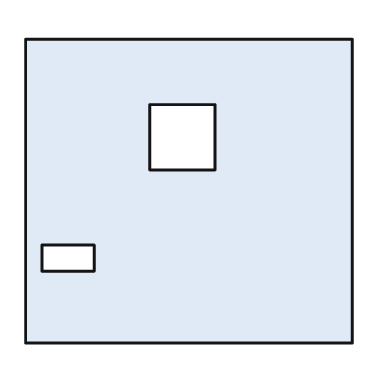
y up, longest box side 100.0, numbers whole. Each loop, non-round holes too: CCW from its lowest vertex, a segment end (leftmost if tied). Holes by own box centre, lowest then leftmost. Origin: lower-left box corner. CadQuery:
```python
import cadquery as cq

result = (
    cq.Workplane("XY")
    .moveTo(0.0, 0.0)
    .lineTo(100.0, 0.0)
    .lineTo(100.0, 93.0)
    .lineTo(0.0, 93.0)
    .close()
    .moveTo(5.0, 22.0)
    .lineTo(21.0, 22.0)
    .lineTo(21.0, 30.0)
    .lineTo(5.0, 30.0)
    .close()
    .moveTo(38.0, 53.0)
    .lineTo(58.0, 53.0)
    .lineTo(58.0, 73.0)
    .lineTo(38.0, 73.0)
    .close()
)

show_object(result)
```